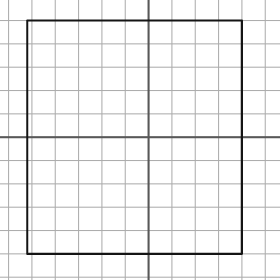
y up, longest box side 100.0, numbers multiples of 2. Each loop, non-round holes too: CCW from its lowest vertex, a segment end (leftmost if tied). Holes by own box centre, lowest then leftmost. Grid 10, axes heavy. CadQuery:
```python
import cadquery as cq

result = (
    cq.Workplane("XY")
    .moveTo(-52.0, -50.0)
    .lineTo(40.0, -50.0)
    .lineTo(40.0, 50.0)
    .lineTo(-52.0, 50.0)
    .close()
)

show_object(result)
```